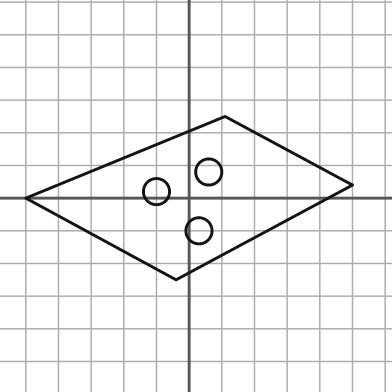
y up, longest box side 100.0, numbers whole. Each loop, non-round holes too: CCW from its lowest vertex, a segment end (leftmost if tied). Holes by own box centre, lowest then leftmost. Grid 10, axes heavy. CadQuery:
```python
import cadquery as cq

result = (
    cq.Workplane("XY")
    .moveTo(-4.0, -25.0)
    .lineTo(50.0, 4.0)
    .lineTo(11.0, 25.0)
    .lineTo(-50.0, 0.0)
    .close()
    .moveTo(3.0, -10.0)
    .circle(4.0)
    .moveTo(-10.0, 2.0)
    .circle(4.0)
    .moveTo(6.0, 8.0)
    .circle(4.0)
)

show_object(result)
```